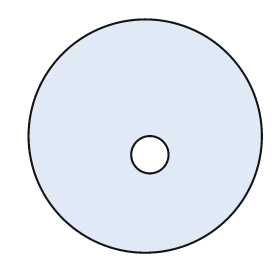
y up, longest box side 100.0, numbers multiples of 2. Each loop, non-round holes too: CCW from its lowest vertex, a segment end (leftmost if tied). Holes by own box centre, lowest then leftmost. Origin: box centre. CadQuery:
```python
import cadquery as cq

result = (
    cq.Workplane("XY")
    .moveTo(0.0, 0.0)
    .circle(50.0)
    .moveTo(2.0, -8.0)
    .circle(8.0)
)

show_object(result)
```